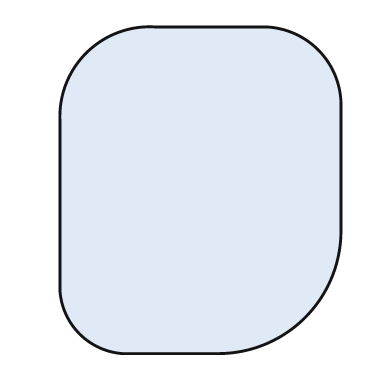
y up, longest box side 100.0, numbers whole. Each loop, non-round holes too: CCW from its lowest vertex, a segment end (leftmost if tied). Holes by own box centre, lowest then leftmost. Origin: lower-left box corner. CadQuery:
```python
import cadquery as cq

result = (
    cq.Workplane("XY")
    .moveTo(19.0, 0.0)
    .lineTo(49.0, 0.0)
    .threePointArc((75.0, 11.0), (86.0, 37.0))
    .lineTo(86.0, 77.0)
    .threePointArc((79.0, 93.0), (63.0, 100.0))
    .lineTo(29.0, 100.0)
    .threePointArc((8.0, 92.0), (0.0, 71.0))
    .lineTo(0.0, 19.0)
    .threePointArc((6.0, 6.0), (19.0, 0.0))
    .close()
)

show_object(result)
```